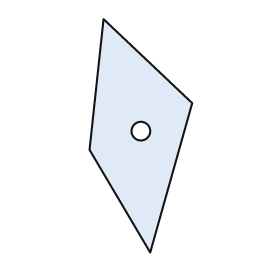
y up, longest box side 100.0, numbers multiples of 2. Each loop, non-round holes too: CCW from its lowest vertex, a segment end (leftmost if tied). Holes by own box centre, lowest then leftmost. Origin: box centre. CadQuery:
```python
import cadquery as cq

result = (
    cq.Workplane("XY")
    .moveTo(4.0, -50.0)
    .lineTo(22.0, 14.0)
    .lineTo(-16.0, 50.0)
    .lineTo(-22.0, -6.0)
    .close()
    .moveTo(0.0, 2.0)
    .circle(4.0)
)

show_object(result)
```